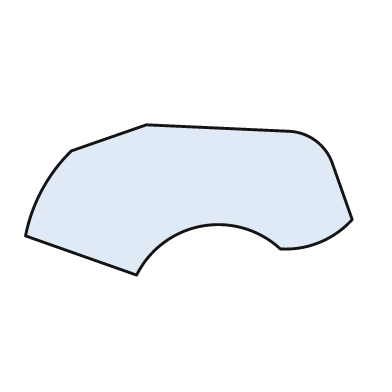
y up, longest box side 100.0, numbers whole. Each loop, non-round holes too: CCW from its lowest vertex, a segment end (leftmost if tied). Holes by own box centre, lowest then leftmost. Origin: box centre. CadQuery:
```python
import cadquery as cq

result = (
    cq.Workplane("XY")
    .moveTo(-16.0, -23.0)
    .threePointArc((4.0, -8.0), (28.0, -15.0))
    .threePointArc((40.0, -13.0), (50.0, -6.0))
    .lineTo(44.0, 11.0)
    .threePointArc((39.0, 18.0), (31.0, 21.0))
    .lineTo(-13.0, 23.0)
    .lineTo(-36.0, 15.0)
    .threePointArc((-45.0, 3.0), (-50.0, -11.0))
    .close()
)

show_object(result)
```